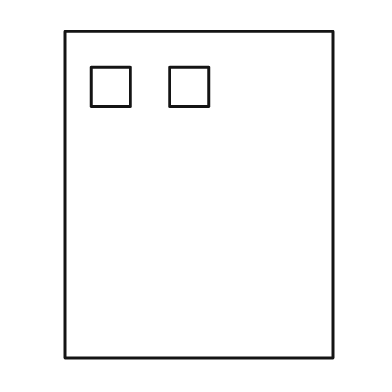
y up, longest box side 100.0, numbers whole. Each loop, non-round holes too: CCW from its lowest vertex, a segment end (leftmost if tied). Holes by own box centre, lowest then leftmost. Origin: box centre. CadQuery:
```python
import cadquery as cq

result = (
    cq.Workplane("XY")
    .moveTo(-41.0, -50.0)
    .lineTo(41.0, -50.0)
    .lineTo(41.0, 50.0)
    .lineTo(-41.0, 50.0)
    .close()
    .moveTo(-33.0, 27.0)
    .lineTo(-21.0, 27.0)
    .lineTo(-21.0, 39.0)
    .lineTo(-33.0, 39.0)
    .close()
    .moveTo(-9.0, 27.0)
    .lineTo(3.0, 27.0)
    .lineTo(3.0, 39.0)
    .lineTo(-9.0, 39.0)
    .close()
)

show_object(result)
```